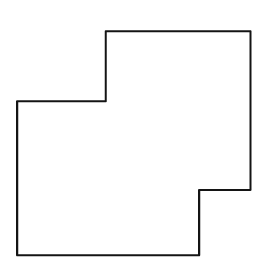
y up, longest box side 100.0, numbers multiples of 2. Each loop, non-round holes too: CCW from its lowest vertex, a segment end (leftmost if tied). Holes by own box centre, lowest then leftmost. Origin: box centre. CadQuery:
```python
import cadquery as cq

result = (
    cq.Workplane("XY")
    .moveTo(-50.0, -48.0)
    .lineTo(28.0, -48.0)
    .lineTo(28.0, -20.0)
    .lineTo(50.0, -20.0)
    .lineTo(50.0, 48.0)
    .lineTo(-12.0, 48.0)
    .lineTo(-12.0, 18.0)
    .lineTo(-50.0, 18.0)
    .close()
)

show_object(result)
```